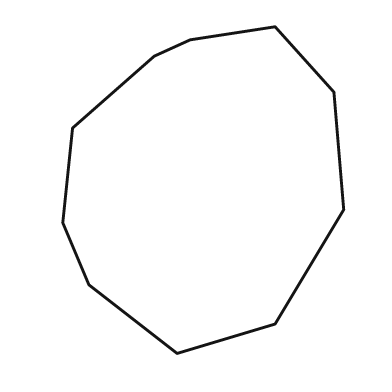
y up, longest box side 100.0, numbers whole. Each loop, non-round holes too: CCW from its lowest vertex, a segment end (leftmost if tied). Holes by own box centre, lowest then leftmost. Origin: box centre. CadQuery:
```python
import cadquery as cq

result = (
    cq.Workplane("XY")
    .moveTo(-8.0, -50.0)
    .lineTo(22.0, -41.0)
    .lineTo(43.0, -6.0)
    .lineTo(40.0, 30.0)
    .lineTo(22.0, 50.0)
    .lineTo(-4.0, 46.0)
    .lineTo(-15.0, 41.0)
    .lineTo(-40.0, 19.0)
    .lineTo(-43.0, -10.0)
    .lineTo(-35.0, -29.0)
    .close()
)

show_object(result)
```